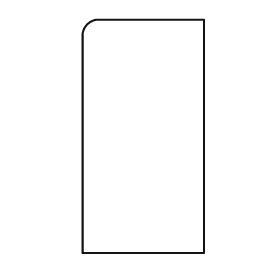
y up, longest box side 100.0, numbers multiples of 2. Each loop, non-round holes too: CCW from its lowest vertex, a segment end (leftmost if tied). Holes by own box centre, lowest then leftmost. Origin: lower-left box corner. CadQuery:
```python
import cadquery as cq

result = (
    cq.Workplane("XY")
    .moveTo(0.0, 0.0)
    .lineTo(52.0, 0.0)
    .lineTo(52.0, 100.0)
    .lineTo(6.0, 100.0)
    .threePointArc((2.0, 98.0), (0.0, 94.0))
    .close()
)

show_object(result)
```